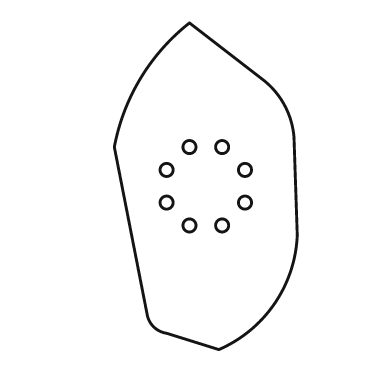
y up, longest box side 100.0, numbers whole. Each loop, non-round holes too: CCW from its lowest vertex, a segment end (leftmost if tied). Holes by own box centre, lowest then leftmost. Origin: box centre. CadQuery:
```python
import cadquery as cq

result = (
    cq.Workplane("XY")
    .moveTo(4.0, -50.0)
    .threePointArc((21.0, -36.0), (28.0, -15.0))
    .lineTo(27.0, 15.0)
    .threePointArc((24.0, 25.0), (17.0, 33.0))
    .lineTo(-5.0, 50.0)
    .threePointArc((-20.0, 33.0), (-28.0, 12.0))
    .lineTo(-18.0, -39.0)
    .threePointArc((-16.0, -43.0), (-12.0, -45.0))
    .close()
    .moveTo(-5.0, -12.0)
    .circle(2.0)
    .moveTo(5.0, -12.0)
    .circle(2.0)
    .moveTo(-12.0, -5.0)
    .circle(2.0)
    .moveTo(12.0, -5.0)
    .circle(2.0)
    .moveTo(-12.0, 5.0)
    .circle(2.0)
    .moveTo(12.0, 5.0)
    .circle(2.0)
    .moveTo(-5.0, 12.0)
    .circle(2.0)
    .moveTo(5.0, 12.0)
    .circle(2.0)
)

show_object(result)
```